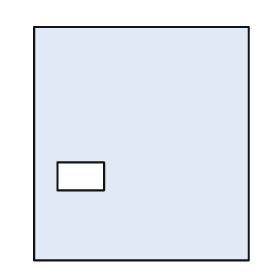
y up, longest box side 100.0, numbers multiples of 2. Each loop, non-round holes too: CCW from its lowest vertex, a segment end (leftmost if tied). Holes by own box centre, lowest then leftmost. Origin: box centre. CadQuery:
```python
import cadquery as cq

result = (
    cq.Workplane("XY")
    .moveTo(-46.0, -50.0)
    .lineTo(46.0, -50.0)
    .lineTo(46.0, 50.0)
    .lineTo(-46.0, 50.0)
    .close()
    .moveTo(-36.0, -20.0)
    .lineTo(-16.0, -20.0)
    .lineTo(-16.0, -8.0)
    .lineTo(-36.0, -8.0)
    .close()
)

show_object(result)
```